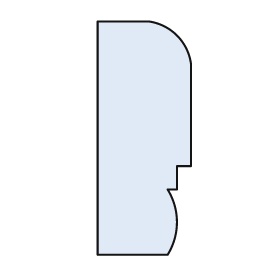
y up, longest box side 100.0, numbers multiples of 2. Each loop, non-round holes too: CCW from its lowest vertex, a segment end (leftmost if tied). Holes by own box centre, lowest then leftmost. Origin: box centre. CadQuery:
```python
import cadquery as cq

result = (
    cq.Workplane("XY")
    .moveTo(-20.0, -50.0)
    .lineTo(10.0, -50.0)
    .threePointArc((14.0, -36.0), (10.0, -22.0))
    .lineTo(14.0, -22.0)
    .lineTo(14.0, -12.0)
    .lineTo(20.0, -12.0)
    .lineTo(20.0, 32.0)
    .threePointArc((14.0, 44.0), (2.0, 50.0))
    .lineTo(-20.0, 50.0)
    .close()
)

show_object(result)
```